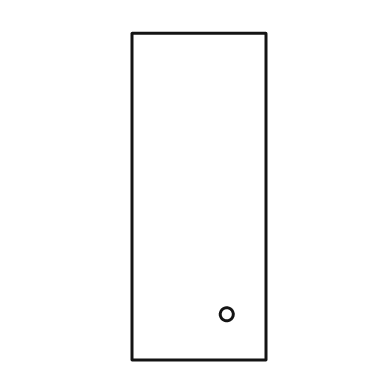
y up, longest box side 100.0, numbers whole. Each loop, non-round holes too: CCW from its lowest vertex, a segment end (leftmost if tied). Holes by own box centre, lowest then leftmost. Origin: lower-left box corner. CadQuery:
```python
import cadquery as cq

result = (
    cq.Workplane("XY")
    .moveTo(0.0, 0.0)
    .lineTo(41.0, 0.0)
    .lineTo(41.0, 100.0)
    .lineTo(0.0, 100.0)
    .close()
    .moveTo(29.0, 14.0)
    .circle(2.0)
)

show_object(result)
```